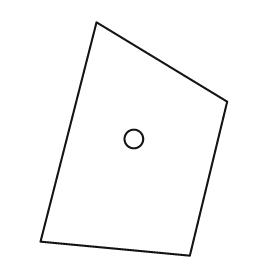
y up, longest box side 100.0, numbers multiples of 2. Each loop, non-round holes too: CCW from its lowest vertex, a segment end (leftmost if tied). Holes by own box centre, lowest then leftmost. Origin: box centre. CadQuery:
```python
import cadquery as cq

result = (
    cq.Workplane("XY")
    .moveTo(24.0, -50.0)
    .lineTo(40.0, 16.0)
    .lineTo(-16.0, 50.0)
    .lineTo(-40.0, -44.0)
    .close()
    .moveTo(0.0, 0.0)
    .circle(4.0)
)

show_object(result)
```